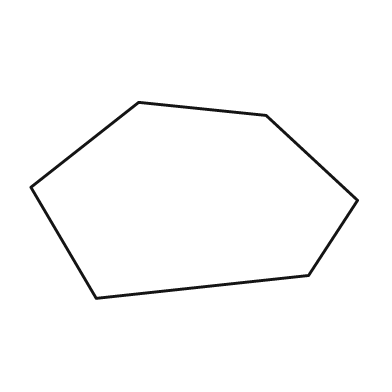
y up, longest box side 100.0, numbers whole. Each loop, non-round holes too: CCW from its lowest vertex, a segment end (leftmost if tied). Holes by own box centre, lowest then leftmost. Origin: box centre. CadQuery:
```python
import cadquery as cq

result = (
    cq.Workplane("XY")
    .moveTo(-30.0, -30.0)
    .lineTo(35.0, -23.0)
    .lineTo(50.0, 0.0)
    .lineTo(22.0, 26.0)
    .lineTo(-17.0, 30.0)
    .lineTo(-50.0, 4.0)
    .close()
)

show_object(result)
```